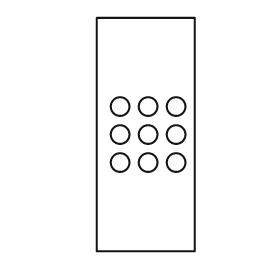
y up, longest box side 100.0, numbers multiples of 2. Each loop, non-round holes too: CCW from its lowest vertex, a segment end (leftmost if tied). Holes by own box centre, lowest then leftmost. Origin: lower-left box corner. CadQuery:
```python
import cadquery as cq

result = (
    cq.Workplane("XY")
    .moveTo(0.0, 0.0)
    .lineTo(42.0, 0.0)
    .lineTo(42.0, 100.0)
    .lineTo(0.0, 100.0)
    .close()
    .moveTo(10.0, 38.0)
    .circle(4.0)
    .moveTo(22.0, 38.0)
    .circle(4.0)
    .moveTo(34.0, 38.0)
    .circle(4.0)
    .moveTo(10.0, 50.0)
    .circle(4.0)
    .moveTo(22.0, 50.0)
    .circle(4.0)
    .moveTo(34.0, 50.0)
    .circle(4.0)
    .moveTo(10.0, 62.0)
    .circle(4.0)
    .moveTo(22.0, 62.0)
    .circle(4.0)
    .moveTo(34.0, 62.0)
    .circle(4.0)
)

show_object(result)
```